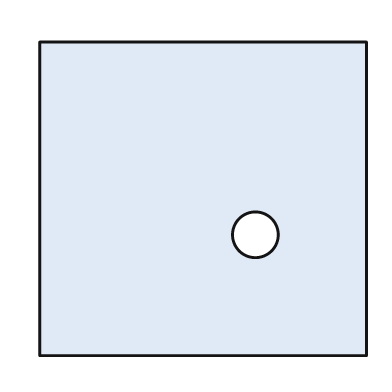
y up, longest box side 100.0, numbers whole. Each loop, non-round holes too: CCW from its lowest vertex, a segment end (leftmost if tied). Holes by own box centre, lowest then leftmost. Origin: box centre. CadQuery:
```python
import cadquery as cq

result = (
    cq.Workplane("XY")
    .moveTo(-50.0, -48.0)
    .lineTo(50.0, -48.0)
    .lineTo(50.0, 48.0)
    .lineTo(-50.0, 48.0)
    .close()
    .moveTo(16.0, -11.0)
    .circle(7.0)
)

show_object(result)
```